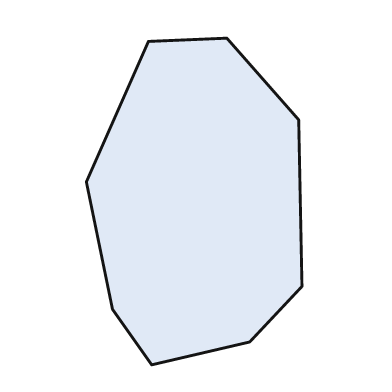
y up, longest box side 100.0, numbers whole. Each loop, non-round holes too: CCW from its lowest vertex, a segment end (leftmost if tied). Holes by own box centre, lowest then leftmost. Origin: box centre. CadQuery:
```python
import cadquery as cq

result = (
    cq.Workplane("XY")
    .moveTo(-13.0, -50.0)
    .lineTo(17.0, -43.0)
    .lineTo(33.0, -26.0)
    .lineTo(32.0, 25.0)
    .lineTo(10.0, 50.0)
    .lineTo(-14.0, 49.0)
    .lineTo(-33.0, 6.0)
    .lineTo(-25.0, -33.0)
    .close()
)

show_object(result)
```